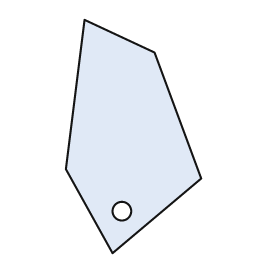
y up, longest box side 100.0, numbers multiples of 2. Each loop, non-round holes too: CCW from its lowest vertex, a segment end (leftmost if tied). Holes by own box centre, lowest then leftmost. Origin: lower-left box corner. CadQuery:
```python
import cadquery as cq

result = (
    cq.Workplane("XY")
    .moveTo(20.0, 0.0)
    .lineTo(58.0, 32.0)
    .lineTo(38.0, 86.0)
    .lineTo(8.0, 100.0)
    .lineTo(0.0, 36.0)
    .close()
    .moveTo(24.0, 18.0)
    .circle(4.0)
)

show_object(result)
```